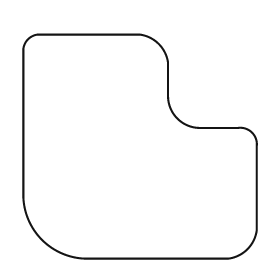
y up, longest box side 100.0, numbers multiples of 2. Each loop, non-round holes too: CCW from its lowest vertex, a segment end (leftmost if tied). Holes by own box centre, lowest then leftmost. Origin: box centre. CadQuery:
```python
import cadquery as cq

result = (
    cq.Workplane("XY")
    .moveTo(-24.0, -48.0)
    .lineTo(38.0, -48.0)
    .threePointArc((46.0, -44.0), (50.0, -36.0))
    .lineTo(50.0, 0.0)
    .threePointArc((48.0, 6.0), (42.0, 8.0))
    .lineTo(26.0, 8.0)
    .threePointArc((16.0, 12.0), (12.0, 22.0))
    .lineTo(12.0, 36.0)
    .threePointArc((8.0, 44.0), (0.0, 48.0))
    .lineTo(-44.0, 48.0)
    .threePointArc((-48.0, 46.0), (-50.0, 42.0))
    .lineTo(-50.0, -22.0)
    .threePointArc((-42.0, -40.0), (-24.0, -48.0))
    .close()
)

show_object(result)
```